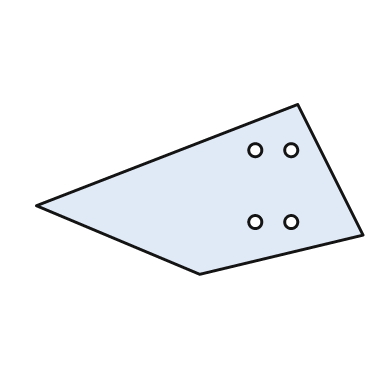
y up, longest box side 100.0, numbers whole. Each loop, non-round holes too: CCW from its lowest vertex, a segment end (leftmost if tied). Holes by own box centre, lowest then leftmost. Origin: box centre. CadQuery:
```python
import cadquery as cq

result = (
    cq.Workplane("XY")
    .moveTo(0.0, -26.0)
    .lineTo(50.0, -14.0)
    .lineTo(30.0, 26.0)
    .lineTo(-50.0, -5.0)
    .close()
    .moveTo(17.0, -10.0)
    .circle(2.0)
    .moveTo(28.0, -10.0)
    .circle(2.0)
    .moveTo(17.0, 12.0)
    .circle(2.0)
    .moveTo(28.0, 12.0)
    .circle(2.0)
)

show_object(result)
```